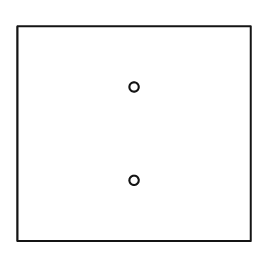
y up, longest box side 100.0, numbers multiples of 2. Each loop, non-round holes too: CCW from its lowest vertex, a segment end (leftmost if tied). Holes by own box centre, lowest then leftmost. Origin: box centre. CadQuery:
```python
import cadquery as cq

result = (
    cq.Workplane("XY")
    .moveTo(-50.0, -46.0)
    .lineTo(50.0, -46.0)
    .lineTo(50.0, 46.0)
    .lineTo(-50.0, 46.0)
    .close()
    .moveTo(0.0, -20.0)
    .circle(2.0)
    .moveTo(0.0, 20.0)
    .circle(2.0)
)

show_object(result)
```